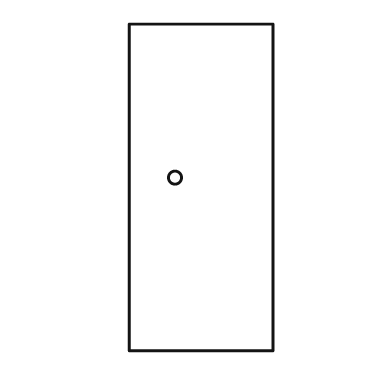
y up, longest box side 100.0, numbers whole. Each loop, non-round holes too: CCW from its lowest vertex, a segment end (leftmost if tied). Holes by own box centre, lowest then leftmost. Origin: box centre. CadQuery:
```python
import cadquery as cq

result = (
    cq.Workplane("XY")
    .moveTo(-22.0, -50.0)
    .lineTo(22.0, -50.0)
    .lineTo(22.0, 50.0)
    .lineTo(-22.0, 50.0)
    .close()
    .moveTo(-8.0, 3.0)
    .circle(2.0)
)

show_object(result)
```